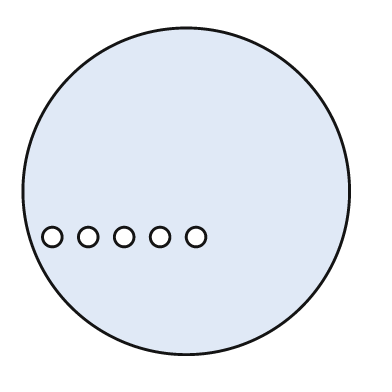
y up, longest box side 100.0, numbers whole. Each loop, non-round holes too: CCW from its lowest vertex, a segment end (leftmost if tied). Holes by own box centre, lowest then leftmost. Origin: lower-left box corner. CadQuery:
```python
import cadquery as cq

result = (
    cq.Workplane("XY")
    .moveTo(50.0, 50.0)
    .circle(50.0)
    .moveTo(9.0, 36.0)
    .circle(3.0)
    .moveTo(20.0, 36.0)
    .circle(3.0)
    .moveTo(31.0, 36.0)
    .circle(3.0)
    .moveTo(42.0, 36.0)
    .circle(3.0)
    .moveTo(53.0, 36.0)
    .circle(3.0)
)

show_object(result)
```